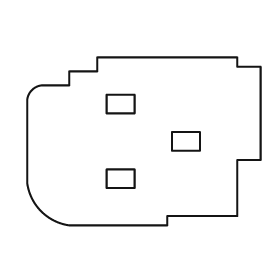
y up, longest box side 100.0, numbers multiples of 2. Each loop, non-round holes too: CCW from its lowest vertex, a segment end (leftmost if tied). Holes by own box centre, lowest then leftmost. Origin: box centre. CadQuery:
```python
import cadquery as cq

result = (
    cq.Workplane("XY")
    .moveTo(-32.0, -36.0)
    .lineTo(10.0, -36.0)
    .lineTo(10.0, -32.0)
    .lineTo(40.0, -32.0)
    .lineTo(40.0, -8.0)
    .lineTo(50.0, -8.0)
    .lineTo(50.0, 32.0)
    .lineTo(40.0, 32.0)
    .lineTo(40.0, 36.0)
    .lineTo(-20.0, 36.0)
    .lineTo(-20.0, 30.0)
    .lineTo(-32.0, 30.0)
    .lineTo(-32.0, 24.0)
    .lineTo(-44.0, 24.0)
    .threePointArc((-48.0, 22.0), (-50.0, 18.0))
    .lineTo(-50.0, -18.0)
    .threePointArc((-44.0, -30.0), (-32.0, -36.0))
    .close()
    .moveTo(-16.0, -20.0)
    .lineTo(-4.0, -20.0)
    .lineTo(-4.0, -12.0)
    .lineTo(-16.0, -12.0)
    .close()
    .moveTo(12.0, -4.0)
    .lineTo(24.0, -4.0)
    .lineTo(24.0, 4.0)
    .lineTo(12.0, 4.0)
    .close()
    .moveTo(-16.0, 12.0)
    .lineTo(-4.0, 12.0)
    .lineTo(-4.0, 20.0)
    .lineTo(-16.0, 20.0)
    .close()
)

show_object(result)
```